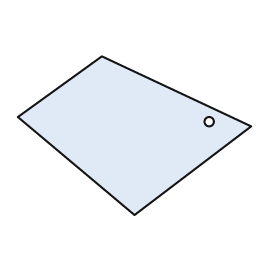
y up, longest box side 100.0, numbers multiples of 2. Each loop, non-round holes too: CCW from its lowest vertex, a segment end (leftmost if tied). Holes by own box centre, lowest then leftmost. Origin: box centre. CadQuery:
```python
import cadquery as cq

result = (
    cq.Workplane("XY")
    .moveTo(0.0, -34.0)
    .lineTo(50.0, 4.0)
    .lineTo(-14.0, 34.0)
    .lineTo(-50.0, 8.0)
    .close()
    .moveTo(32.0, 6.0)
    .circle(2.0)
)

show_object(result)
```